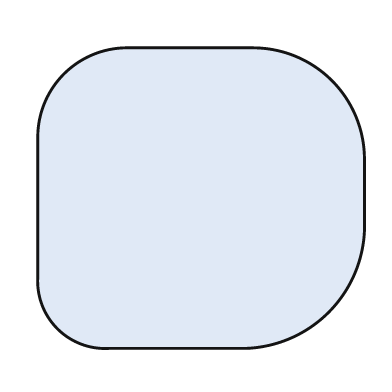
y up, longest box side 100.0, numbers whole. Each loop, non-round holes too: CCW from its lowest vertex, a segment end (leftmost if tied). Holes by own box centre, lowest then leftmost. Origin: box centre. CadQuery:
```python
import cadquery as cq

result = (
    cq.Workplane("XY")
    .moveTo(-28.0, -46.0)
    .lineTo(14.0, -46.0)
    .threePointArc((39.0, -35.0), (50.0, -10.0))
    .lineTo(50.0, 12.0)
    .threePointArc((40.0, 36.0), (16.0, 46.0))
    .lineTo(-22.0, 46.0)
    .threePointArc((-42.0, 38.0), (-50.0, 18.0))
    .lineTo(-50.0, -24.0)
    .threePointArc((-44.0, -40.0), (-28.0, -46.0))
    .close()
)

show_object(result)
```